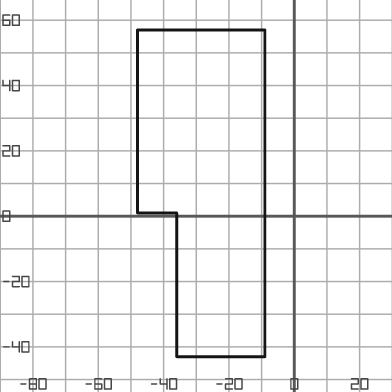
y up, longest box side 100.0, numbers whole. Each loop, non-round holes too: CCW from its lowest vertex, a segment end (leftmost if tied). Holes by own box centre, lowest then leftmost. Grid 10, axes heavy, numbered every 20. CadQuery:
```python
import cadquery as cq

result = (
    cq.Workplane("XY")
    .moveTo(-36.0, -43.0)
    .lineTo(-9.0, -43.0)
    .lineTo(-9.0, 57.0)
    .lineTo(-48.0, 57.0)
    .lineTo(-48.0, 1.0)
    .lineTo(-36.0, 1.0)
    .close()
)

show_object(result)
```